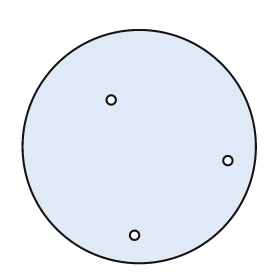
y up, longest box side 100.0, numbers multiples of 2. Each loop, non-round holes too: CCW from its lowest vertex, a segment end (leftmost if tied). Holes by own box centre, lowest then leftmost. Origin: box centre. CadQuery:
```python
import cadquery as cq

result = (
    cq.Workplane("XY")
    .moveTo(0.0, 0.0)
    .circle(50.0)
    .moveTo(-2.0, -38.0)
    .circle(2.0)
    .moveTo(38.0, -6.0)
    .circle(2.0)
    .moveTo(-12.0, 20.0)
    .circle(2.0)
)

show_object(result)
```